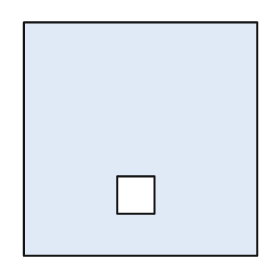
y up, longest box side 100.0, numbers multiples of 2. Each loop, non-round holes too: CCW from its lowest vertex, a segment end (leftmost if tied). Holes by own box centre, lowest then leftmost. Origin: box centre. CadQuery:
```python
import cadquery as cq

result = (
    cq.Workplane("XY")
    .moveTo(-50.0, -50.0)
    .lineTo(50.0, -50.0)
    .lineTo(50.0, 50.0)
    .lineTo(-50.0, 50.0)
    .close()
    .moveTo(-10.0, -32.0)
    .lineTo(6.0, -32.0)
    .lineTo(6.0, -16.0)
    .lineTo(-10.0, -16.0)
    .close()
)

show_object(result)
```